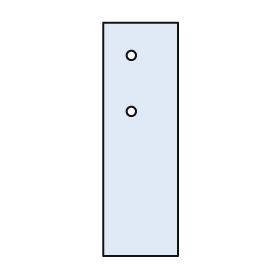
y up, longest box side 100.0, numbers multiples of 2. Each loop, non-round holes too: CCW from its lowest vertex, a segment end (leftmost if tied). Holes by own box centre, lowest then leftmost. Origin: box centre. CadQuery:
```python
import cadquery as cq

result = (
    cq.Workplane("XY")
    .moveTo(-16.0, -50.0)
    .lineTo(16.0, -50.0)
    .lineTo(16.0, 50.0)
    .lineTo(-16.0, 50.0)
    .close()
    .moveTo(-4.0, 12.0)
    .circle(2.0)
    .moveTo(-4.0, 36.0)
    .circle(2.0)
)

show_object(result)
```